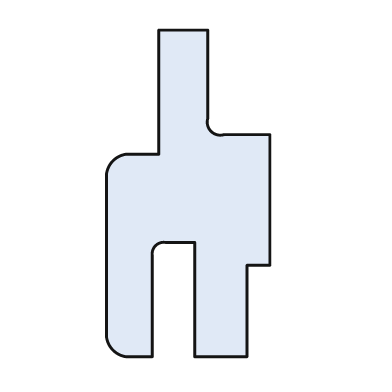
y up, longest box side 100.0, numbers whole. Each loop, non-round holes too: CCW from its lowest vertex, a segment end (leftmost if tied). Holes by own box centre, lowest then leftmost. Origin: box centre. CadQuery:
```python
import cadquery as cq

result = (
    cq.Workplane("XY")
    .moveTo(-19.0, -50.0)
    .lineTo(-11.0, -50.0)
    .lineTo(-11.0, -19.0)
    .threePointArc((-10.0, -16.0), (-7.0, -15.0))
    .lineTo(2.0, -15.0)
    .lineTo(2.0, -50.0)
    .lineTo(18.0, -50.0)
    .lineTo(18.0, -22.0)
    .lineTo(25.0, -22.0)
    .lineTo(25.0, 18.0)
    .lineTo(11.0, 18.0)
    .threePointArc((7.0, 19.0), (6.0, 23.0))
    .lineTo(6.0, 50.0)
    .lineTo(-9.0, 50.0)
    .lineTo(-9.0, 12.0)
    .lineTo(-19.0, 12.0)
    .threePointArc((-23.0, 10.0), (-25.0, 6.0))
    .lineTo(-25.0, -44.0)
    .threePointArc((-23.0, -48.0), (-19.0, -50.0))
    .close()
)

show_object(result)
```